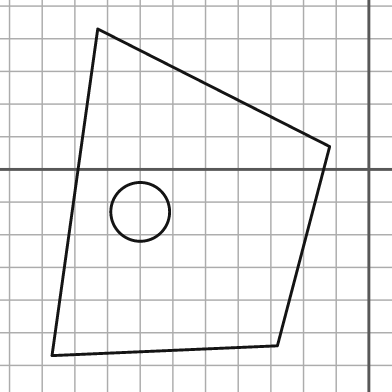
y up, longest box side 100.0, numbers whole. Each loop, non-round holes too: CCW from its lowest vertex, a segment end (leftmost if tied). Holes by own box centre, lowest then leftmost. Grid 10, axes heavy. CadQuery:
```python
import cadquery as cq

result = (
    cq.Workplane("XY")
    .moveTo(-97.0, -57.0)
    .lineTo(-28.0, -54.0)
    .lineTo(-12.0, 7.0)
    .lineTo(-83.0, 43.0)
    .close()
    .moveTo(-70.0, -13.0)
    .circle(9.0)
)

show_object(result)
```